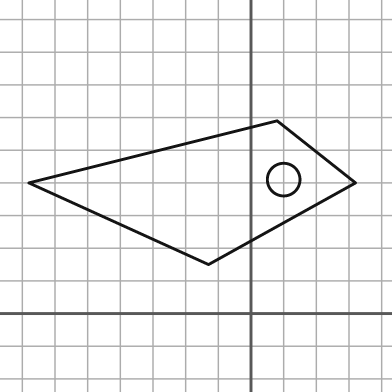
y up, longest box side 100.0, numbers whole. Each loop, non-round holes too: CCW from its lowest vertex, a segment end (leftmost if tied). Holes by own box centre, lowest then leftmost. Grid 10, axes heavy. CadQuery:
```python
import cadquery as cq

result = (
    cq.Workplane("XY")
    .moveTo(-13.0, 15.0)
    .lineTo(32.0, 40.0)
    .lineTo(8.0, 59.0)
    .lineTo(-68.0, 40.0)
    .close()
    .moveTo(10.0, 41.0)
    .circle(5.0)
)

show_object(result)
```